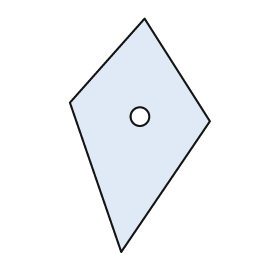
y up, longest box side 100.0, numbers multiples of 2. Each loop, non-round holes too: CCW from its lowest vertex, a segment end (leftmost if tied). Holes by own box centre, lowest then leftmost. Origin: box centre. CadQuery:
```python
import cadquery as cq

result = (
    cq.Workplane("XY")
    .moveTo(-8.0, -50.0)
    .lineTo(30.0, 6.0)
    .lineTo(2.0, 50.0)
    .lineTo(-30.0, 14.0)
    .close()
    .moveTo(0.0, 8.0)
    .circle(4.0)
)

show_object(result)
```